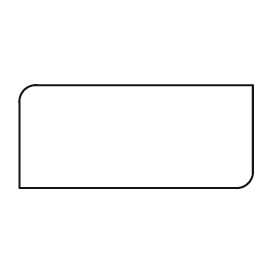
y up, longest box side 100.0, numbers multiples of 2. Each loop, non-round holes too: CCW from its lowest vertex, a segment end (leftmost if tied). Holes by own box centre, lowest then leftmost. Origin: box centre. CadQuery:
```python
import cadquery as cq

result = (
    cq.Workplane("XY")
    .moveTo(-50.0, -22.0)
    .lineTo(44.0, -22.0)
    .threePointArc((48.0, -20.0), (50.0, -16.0))
    .lineTo(50.0, 22.0)
    .lineTo(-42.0, 22.0)
    .threePointArc((-48.0, 20.0), (-50.0, 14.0))
    .close()
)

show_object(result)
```